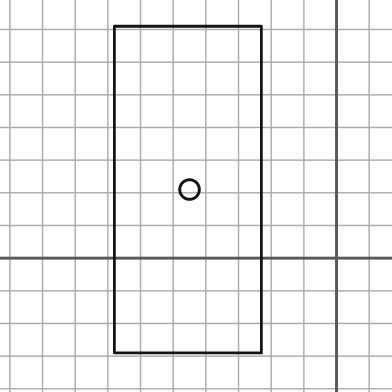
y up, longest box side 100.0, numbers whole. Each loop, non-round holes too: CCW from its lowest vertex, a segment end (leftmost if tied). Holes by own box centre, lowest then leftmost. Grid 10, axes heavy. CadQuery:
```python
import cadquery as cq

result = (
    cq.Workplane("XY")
    .moveTo(-68.0, -29.0)
    .lineTo(-23.0, -29.0)
    .lineTo(-23.0, 71.0)
    .lineTo(-68.0, 71.0)
    .close()
    .moveTo(-45.0, 21.0)
    .circle(3.0)
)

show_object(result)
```